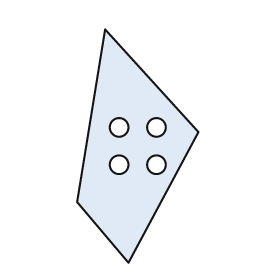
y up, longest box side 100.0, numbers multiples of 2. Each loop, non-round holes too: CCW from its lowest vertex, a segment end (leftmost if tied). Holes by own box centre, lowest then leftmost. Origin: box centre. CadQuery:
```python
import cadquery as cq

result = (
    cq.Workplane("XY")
    .moveTo(-4.0, -50.0)
    .lineTo(26.0, 6.0)
    .lineTo(-14.0, 50.0)
    .lineTo(-26.0, -24.0)
    .close()
    .moveTo(-8.0, -8.0)
    .circle(4.0)
    .moveTo(8.0, -8.0)
    .circle(4.0)
    .moveTo(-8.0, 8.0)
    .circle(4.0)
    .moveTo(8.0, 8.0)
    .circle(4.0)
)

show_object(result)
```